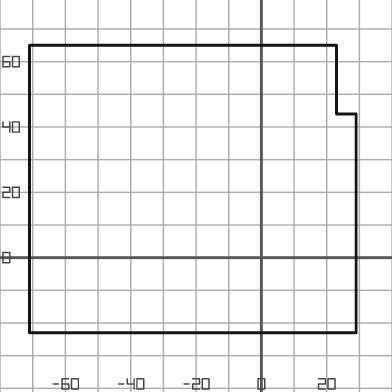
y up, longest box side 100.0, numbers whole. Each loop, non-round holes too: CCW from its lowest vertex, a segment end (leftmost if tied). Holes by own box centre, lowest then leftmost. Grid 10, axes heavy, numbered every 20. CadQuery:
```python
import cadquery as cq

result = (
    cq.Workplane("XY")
    .moveTo(-71.0, -23.0)
    .lineTo(29.0, -23.0)
    .lineTo(29.0, 44.0)
    .lineTo(23.0, 44.0)
    .lineTo(23.0, 65.0)
    .lineTo(-71.0, 65.0)
    .close()
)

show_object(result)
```